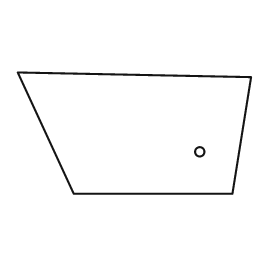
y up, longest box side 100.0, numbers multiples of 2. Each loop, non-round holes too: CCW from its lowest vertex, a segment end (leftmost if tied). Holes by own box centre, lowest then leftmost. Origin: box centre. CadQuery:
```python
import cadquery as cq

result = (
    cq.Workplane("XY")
    .moveTo(-26.0, -26.0)
    .lineTo(42.0, -26.0)
    .lineTo(50.0, 24.0)
    .lineTo(-50.0, 26.0)
    .close()
    .moveTo(28.0, -8.0)
    .circle(2.0)
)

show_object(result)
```